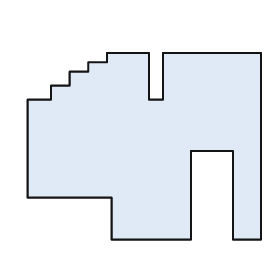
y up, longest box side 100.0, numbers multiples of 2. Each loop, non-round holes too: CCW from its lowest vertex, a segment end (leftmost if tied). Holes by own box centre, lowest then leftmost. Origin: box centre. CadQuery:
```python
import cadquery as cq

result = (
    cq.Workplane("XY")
    .moveTo(-14.0, -40.0)
    .lineTo(20.0, -40.0)
    .lineTo(20.0, -2.0)
    .lineTo(38.0, -2.0)
    .lineTo(38.0, -40.0)
    .lineTo(50.0, -40.0)
    .lineTo(50.0, 40.0)
    .lineTo(8.0, 40.0)
    .lineTo(8.0, 20.0)
    .lineTo(2.0, 20.0)
    .lineTo(2.0, 40.0)
    .lineTo(-16.0, 40.0)
    .lineTo(-16.0, 36.0)
    .lineTo(-24.0, 36.0)
    .lineTo(-24.0, 32.0)
    .lineTo(-32.0, 32.0)
    .lineTo(-32.0, 26.0)
    .lineTo(-40.0, 26.0)
    .lineTo(-40.0, 20.0)
    .lineTo(-50.0, 20.0)
    .lineTo(-50.0, -22.0)
    .lineTo(-14.0, -22.0)
    .close()
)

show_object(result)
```